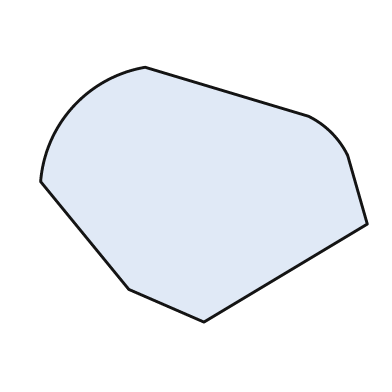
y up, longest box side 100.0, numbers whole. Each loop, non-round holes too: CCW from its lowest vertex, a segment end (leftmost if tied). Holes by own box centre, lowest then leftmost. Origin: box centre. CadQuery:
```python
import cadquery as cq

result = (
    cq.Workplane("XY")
    .moveTo(0.0, -39.0)
    .lineTo(50.0, -9.0)
    .lineTo(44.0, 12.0)
    .threePointArc((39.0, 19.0), (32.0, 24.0))
    .lineTo(-18.0, 39.0)
    .threePointArc((-40.0, 27.0), (-50.0, 4.0))
    .lineTo(-23.0, -29.0)
    .close()
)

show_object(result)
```